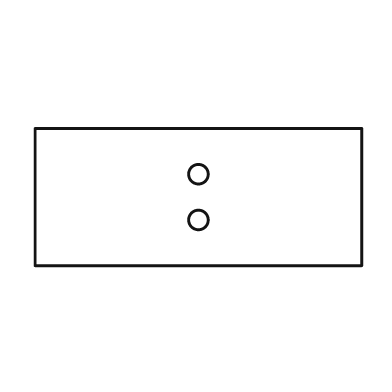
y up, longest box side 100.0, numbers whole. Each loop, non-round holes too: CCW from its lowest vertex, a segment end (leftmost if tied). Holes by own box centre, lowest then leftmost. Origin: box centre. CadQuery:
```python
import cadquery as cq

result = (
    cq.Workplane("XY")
    .moveTo(-50.0, -21.0)
    .lineTo(50.0, -21.0)
    .lineTo(50.0, 21.0)
    .lineTo(-50.0, 21.0)
    .close()
    .moveTo(0.0, -7.0)
    .circle(3.0)
    .moveTo(0.0, 7.0)
    .circle(3.0)
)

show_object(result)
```